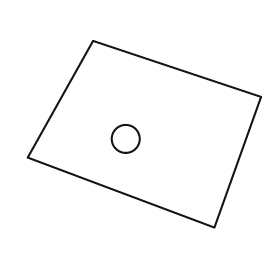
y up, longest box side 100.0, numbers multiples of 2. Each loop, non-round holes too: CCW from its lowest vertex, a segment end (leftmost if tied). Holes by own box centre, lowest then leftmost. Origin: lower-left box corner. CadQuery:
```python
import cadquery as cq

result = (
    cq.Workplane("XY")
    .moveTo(80.0, 0.0)
    .lineTo(100.0, 56.0)
    .lineTo(28.0, 80.0)
    .lineTo(0.0, 30.0)
    .close()
    .moveTo(42.0, 38.0)
    .circle(6.0)
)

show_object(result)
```